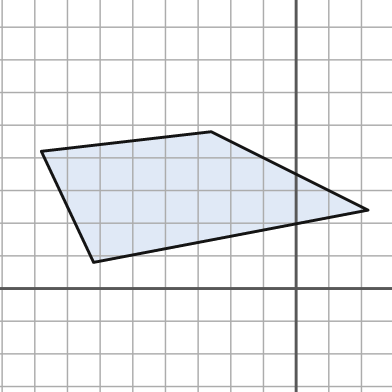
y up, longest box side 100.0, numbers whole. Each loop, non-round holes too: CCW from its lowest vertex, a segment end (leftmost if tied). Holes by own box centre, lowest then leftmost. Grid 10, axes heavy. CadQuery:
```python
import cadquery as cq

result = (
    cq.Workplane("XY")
    .moveTo(-62.0, 8.0)
    .lineTo(22.0, 24.0)
    .lineTo(-26.0, 48.0)
    .lineTo(-78.0, 42.0)
    .close()
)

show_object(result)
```